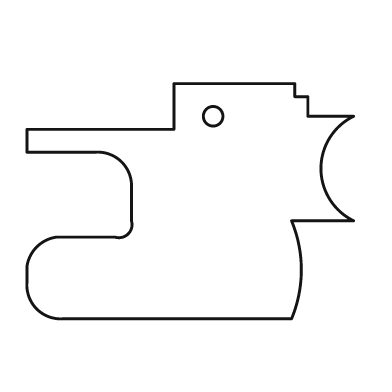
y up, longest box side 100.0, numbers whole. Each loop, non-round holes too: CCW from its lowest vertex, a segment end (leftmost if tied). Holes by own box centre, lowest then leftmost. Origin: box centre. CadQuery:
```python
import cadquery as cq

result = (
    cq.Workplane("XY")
    .moveTo(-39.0, -36.0)
    .lineTo(31.0, -36.0)
    .threePointArc((34.0, -21.0), (31.0, -6.0))
    .lineTo(50.0, -6.0)
    .threePointArc((40.0, 10.0), (50.0, 26.0))
    .lineTo(36.0, 26.0)
    .lineTo(36.0, 32.0)
    .lineTo(32.0, 32.0)
    .lineTo(32.0, 36.0)
    .lineTo(-5.0, 36.0)
    .lineTo(-5.0, 22.0)
    .lineTo(-50.0, 22.0)
    .lineTo(-50.0, 15.0)
    .lineTo(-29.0, 15.0)
    .threePointArc((-21.0, 12.0), (-18.0, 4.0))
    .lineTo(-18.0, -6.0)
    .threePointArc((-19.0, -10.0), (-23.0, -11.0))
    .lineTo(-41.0, -11.0)
    .threePointArc((-47.0, -14.0), (-50.0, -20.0))
    .lineTo(-50.0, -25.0)
    .threePointArc((-47.0, -33.0), (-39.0, -36.0))
    .close()
    .moveTo(7.0, 26.0)
    .circle(3.0)
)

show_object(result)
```